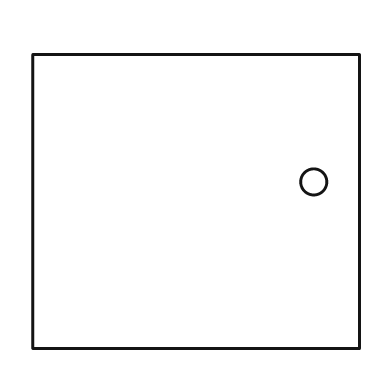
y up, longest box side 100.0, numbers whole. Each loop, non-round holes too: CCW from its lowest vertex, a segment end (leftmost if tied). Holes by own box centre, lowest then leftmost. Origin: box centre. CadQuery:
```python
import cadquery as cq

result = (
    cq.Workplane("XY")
    .moveTo(-50.0, -45.0)
    .lineTo(50.0, -45.0)
    .lineTo(50.0, 45.0)
    .lineTo(-50.0, 45.0)
    .close()
    .moveTo(36.0, 6.0)
    .circle(4.0)
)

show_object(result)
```